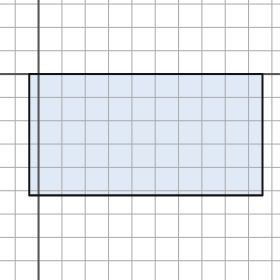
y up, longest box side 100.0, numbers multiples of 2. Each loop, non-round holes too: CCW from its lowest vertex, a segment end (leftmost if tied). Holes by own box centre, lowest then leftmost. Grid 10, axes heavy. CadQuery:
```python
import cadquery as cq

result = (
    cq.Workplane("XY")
    .moveTo(-4.0, -52.0)
    .lineTo(96.0, -52.0)
    .lineTo(96.0, 0.0)
    .lineTo(-4.0, 0.0)
    .close()
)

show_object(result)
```